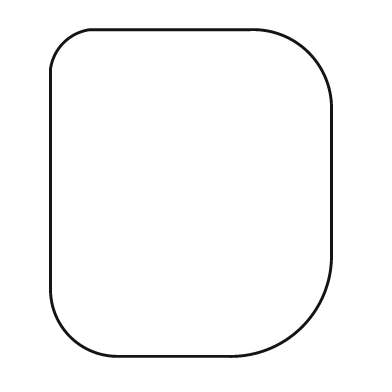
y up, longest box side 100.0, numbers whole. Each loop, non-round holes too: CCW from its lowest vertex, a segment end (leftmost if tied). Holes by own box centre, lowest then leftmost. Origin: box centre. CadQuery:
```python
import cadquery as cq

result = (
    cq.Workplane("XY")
    .moveTo(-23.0, -50.0)
    .lineTo(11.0, -50.0)
    .threePointArc((34.0, -41.0), (43.0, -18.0))
    .lineTo(43.0, 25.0)
    .threePointArc((36.0, 43.0), (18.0, 50.0))
    .lineTo(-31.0, 50.0)
    .threePointArc((-39.0, 46.0), (-43.0, 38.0))
    .lineTo(-43.0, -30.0)
    .threePointArc((-37.0, -44.0), (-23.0, -50.0))
    .close()
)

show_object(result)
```